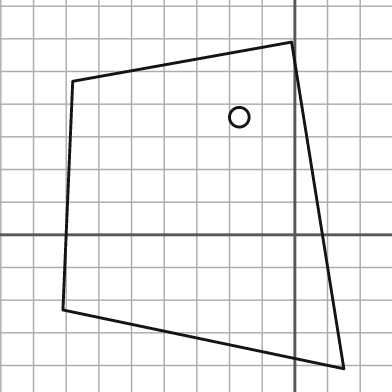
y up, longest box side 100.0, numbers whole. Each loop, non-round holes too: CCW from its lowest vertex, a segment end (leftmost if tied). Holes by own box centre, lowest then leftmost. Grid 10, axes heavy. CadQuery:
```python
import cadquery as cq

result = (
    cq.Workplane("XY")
    .moveTo(15.0, -41.0)
    .lineTo(-1.0, 59.0)
    .lineTo(-68.0, 47.0)
    .lineTo(-71.0, -23.0)
    .close()
    .moveTo(-17.0, 36.0)
    .circle(3.0)
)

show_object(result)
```